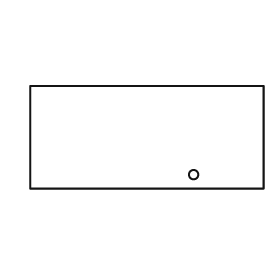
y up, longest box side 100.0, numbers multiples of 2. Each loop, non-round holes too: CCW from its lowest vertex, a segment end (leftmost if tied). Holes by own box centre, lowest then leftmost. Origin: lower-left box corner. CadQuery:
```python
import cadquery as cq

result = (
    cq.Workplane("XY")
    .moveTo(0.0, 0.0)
    .lineTo(100.0, 0.0)
    .lineTo(100.0, 44.0)
    .lineTo(0.0, 44.0)
    .close()
    .moveTo(70.0, 6.0)
    .circle(2.0)
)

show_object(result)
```